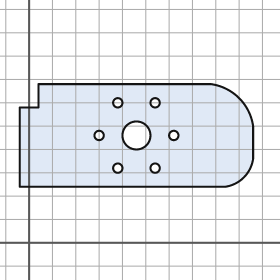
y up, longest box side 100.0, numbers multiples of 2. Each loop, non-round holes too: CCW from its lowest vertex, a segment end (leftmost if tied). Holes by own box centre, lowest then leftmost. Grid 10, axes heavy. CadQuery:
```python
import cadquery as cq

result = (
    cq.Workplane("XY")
    .moveTo(-4.0, 24.0)
    .lineTo(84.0, 24.0)
    .threePointArc((92.0, 28.0), (96.0, 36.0))
    .lineTo(96.0, 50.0)
    .threePointArc((90.0, 62.0), (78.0, 68.0))
    .lineTo(4.0, 68.0)
    .lineTo(4.0, 58.0)
    .lineTo(-4.0, 58.0)
    .close()
    .moveTo(38.0, 32.0)
    .circle(2.0)
    .moveTo(54.0, 32.0)
    .circle(2.0)
    .moveTo(30.0, 46.0)
    .circle(2.0)
    .moveTo(46.0, 46.0)
    .circle(6.0)
    .moveTo(62.0, 46.0)
    .circle(2.0)
    .moveTo(38.0, 60.0)
    .circle(2.0)
    .moveTo(54.0, 60.0)
    .circle(2.0)
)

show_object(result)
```